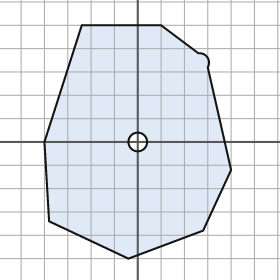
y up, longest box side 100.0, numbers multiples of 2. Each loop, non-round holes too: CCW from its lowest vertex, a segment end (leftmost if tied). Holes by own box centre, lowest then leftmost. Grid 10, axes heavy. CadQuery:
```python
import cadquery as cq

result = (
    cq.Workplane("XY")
    .moveTo(-4.0, -50.0)
    .lineTo(28.0, -38.0)
    .lineTo(40.0, -12.0)
    .lineTo(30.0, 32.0)
    .threePointArc((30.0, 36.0), (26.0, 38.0))
    .lineTo(10.0, 50.0)
    .lineTo(-24.0, 50.0)
    .lineTo(-40.0, 0.0)
    .lineTo(-38.0, -34.0)
    .close()
    .moveTo(0.0, 0.0)
    .circle(4.0)
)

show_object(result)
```